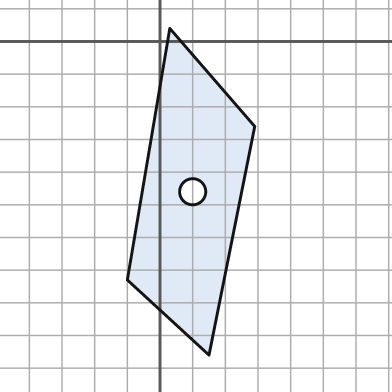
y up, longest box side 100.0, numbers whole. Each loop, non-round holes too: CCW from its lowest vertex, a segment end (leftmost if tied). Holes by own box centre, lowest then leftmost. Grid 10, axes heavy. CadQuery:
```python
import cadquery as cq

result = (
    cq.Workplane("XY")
    .moveTo(15.0, -96.0)
    .lineTo(29.0, -26.0)
    .lineTo(3.0, 4.0)
    .lineTo(-10.0, -73.0)
    .close()
    .moveTo(10.0, -46.0)
    .circle(4.0)
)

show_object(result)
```